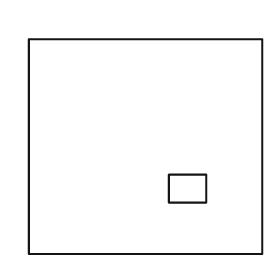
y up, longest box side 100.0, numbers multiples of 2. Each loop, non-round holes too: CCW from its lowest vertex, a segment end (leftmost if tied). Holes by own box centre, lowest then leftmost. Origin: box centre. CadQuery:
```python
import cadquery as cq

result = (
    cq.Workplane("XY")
    .moveTo(-50.0, -46.0)
    .lineTo(50.0, -46.0)
    .lineTo(50.0, 46.0)
    .lineTo(-50.0, 46.0)
    .close()
    .moveTo(10.0, -24.0)
    .lineTo(26.0, -24.0)
    .lineTo(26.0, -12.0)
    .lineTo(10.0, -12.0)
    .close()
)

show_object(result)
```